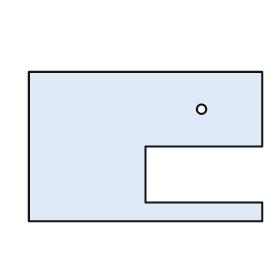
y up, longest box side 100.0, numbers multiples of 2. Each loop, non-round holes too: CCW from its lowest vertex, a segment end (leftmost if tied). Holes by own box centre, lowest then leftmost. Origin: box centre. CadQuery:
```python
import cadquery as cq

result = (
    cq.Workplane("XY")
    .moveTo(-50.0, -32.0)
    .lineTo(50.0, -32.0)
    .lineTo(50.0, -24.0)
    .lineTo(0.0, -24.0)
    .lineTo(0.0, 0.0)
    .lineTo(50.0, 0.0)
    .lineTo(50.0, 32.0)
    .lineTo(-50.0, 32.0)
    .close()
    .moveTo(24.0, 16.0)
    .circle(2.0)
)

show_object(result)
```